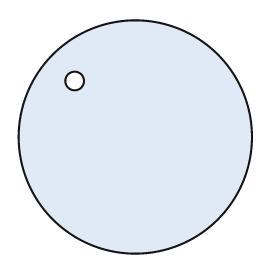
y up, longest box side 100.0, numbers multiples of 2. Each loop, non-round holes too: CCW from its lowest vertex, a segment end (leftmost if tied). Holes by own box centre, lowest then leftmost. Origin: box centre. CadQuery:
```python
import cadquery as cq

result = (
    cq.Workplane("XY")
    .moveTo(0.0, 0.0)
    .circle(50.0)
    .moveTo(-26.0, 24.0)
    .circle(4.0)
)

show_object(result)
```